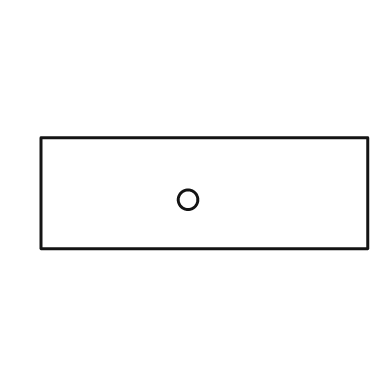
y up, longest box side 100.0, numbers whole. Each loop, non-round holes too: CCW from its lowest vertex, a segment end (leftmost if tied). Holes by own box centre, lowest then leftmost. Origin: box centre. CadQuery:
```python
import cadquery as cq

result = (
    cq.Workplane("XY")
    .moveTo(-50.0, -17.0)
    .lineTo(50.0, -17.0)
    .lineTo(50.0, 17.0)
    .lineTo(-50.0, 17.0)
    .close()
    .moveTo(-5.0, -2.0)
    .circle(3.0)
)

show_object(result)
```